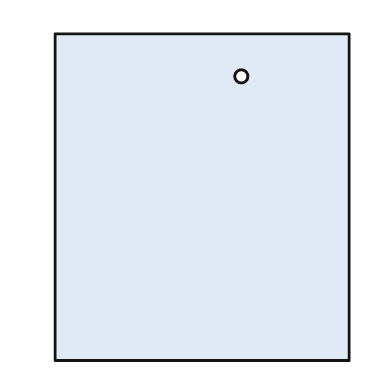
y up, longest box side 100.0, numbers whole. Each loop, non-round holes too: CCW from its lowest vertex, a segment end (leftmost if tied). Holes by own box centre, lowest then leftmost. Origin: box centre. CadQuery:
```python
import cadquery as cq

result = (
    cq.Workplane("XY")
    .moveTo(-45.0, -50.0)
    .lineTo(45.0, -50.0)
    .lineTo(45.0, 50.0)
    .lineTo(-45.0, 50.0)
    .close()
    .moveTo(12.0, 37.0)
    .circle(2.0)
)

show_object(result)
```